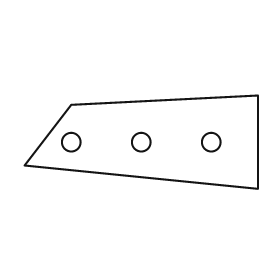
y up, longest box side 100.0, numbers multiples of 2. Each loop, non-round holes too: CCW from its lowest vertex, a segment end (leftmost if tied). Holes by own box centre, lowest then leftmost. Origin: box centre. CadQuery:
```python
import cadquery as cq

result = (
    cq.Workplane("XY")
    .moveTo(50.0, -20.0)
    .lineTo(50.0, 20.0)
    .lineTo(-30.0, 16.0)
    .lineTo(-50.0, -10.0)
    .close()
    .moveTo(-30.0, 0.0)
    .circle(4.0)
    .moveTo(0.0, 0.0)
    .circle(4.0)
    .moveTo(30.0, 0.0)
    .circle(4.0)
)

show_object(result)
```